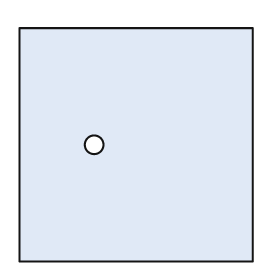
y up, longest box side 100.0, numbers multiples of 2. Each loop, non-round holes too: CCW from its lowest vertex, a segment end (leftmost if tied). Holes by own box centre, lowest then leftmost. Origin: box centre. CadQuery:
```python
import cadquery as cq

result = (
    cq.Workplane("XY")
    .moveTo(-50.0, -50.0)
    .lineTo(50.0, -50.0)
    .lineTo(50.0, 50.0)
    .lineTo(-50.0, 50.0)
    .close()
    .moveTo(-18.0, 0.0)
    .circle(4.0)
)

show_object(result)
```